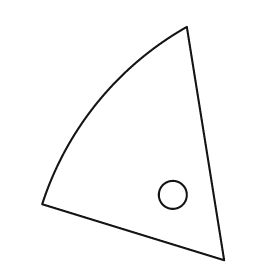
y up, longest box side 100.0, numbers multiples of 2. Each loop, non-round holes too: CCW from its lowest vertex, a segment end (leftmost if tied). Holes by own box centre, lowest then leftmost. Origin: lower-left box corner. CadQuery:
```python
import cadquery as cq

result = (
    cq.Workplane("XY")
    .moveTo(78.0, 0.0)
    .lineTo(62.0, 100.0)
    .threePointArc((24.0, 68.0), (0.0, 24.0))
    .close()
    .moveTo(56.0, 28.0)
    .circle(6.0)
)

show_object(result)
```